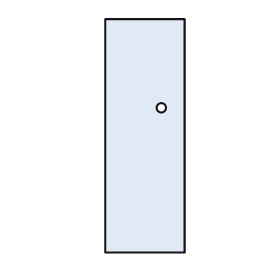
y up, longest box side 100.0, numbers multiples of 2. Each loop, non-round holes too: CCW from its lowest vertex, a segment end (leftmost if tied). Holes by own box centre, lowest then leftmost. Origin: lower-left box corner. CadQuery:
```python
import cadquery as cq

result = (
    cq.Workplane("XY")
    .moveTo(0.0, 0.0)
    .lineTo(34.0, 0.0)
    .lineTo(34.0, 100.0)
    .lineTo(0.0, 100.0)
    .close()
    .moveTo(24.0, 62.0)
    .circle(2.0)
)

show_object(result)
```